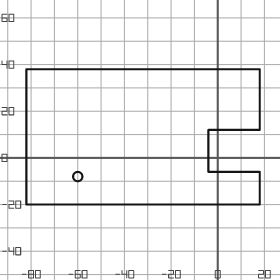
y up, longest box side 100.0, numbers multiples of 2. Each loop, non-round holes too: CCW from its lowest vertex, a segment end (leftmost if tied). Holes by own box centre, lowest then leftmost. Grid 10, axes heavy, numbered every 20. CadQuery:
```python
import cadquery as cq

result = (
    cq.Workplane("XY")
    .moveTo(-82.0, -20.0)
    .lineTo(18.0, -20.0)
    .lineTo(18.0, -6.0)
    .lineTo(-4.0, -6.0)
    .lineTo(-4.0, 12.0)
    .lineTo(18.0, 12.0)
    .lineTo(18.0, 38.0)
    .lineTo(-82.0, 38.0)
    .close()
    .moveTo(-60.0, -8.0)
    .circle(2.0)
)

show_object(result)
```